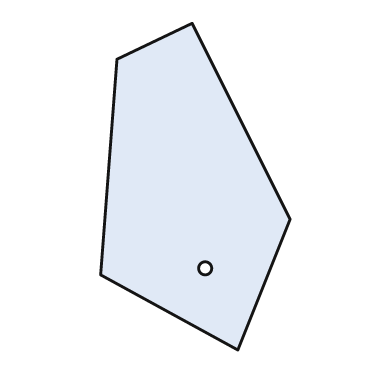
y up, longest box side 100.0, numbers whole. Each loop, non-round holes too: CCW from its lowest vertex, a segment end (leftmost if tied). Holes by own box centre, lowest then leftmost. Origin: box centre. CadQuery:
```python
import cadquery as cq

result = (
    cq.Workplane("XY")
    .moveTo(13.0, -50.0)
    .lineTo(29.0, -10.0)
    .lineTo(-1.0, 50.0)
    .lineTo(-24.0, 39.0)
    .lineTo(-29.0, -27.0)
    .close()
    .moveTo(3.0, -25.0)
    .circle(2.0)
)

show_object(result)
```